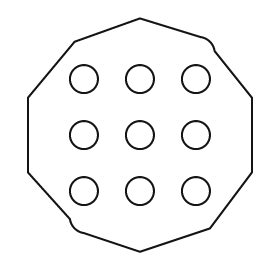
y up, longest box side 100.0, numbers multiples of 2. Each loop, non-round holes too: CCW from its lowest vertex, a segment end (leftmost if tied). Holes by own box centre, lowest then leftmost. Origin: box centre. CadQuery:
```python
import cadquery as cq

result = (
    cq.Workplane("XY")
    .moveTo(0.0, -50.0)
    .lineTo(30.0, -40.0)
    .lineTo(48.0, -16.0)
    .lineTo(48.0, 16.0)
    .lineTo(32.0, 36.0)
    .threePointArc((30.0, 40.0), (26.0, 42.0))
    .lineTo(0.0, 50.0)
    .lineTo(-28.0, 40.0)
    .lineTo(-48.0, 16.0)
    .lineTo(-48.0, -16.0)
    .lineTo(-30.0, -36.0)
    .threePointArc((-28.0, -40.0), (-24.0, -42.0))
    .close()
    .moveTo(-24.0, -24.0)
    .circle(6.0)
    .moveTo(0.0, -24.0)
    .circle(6.0)
    .moveTo(24.0, -24.0)
    .circle(6.0)
    .moveTo(-24.0, 0.0)
    .circle(6.0)
    .moveTo(0.0, 0.0)
    .circle(6.0)
    .moveTo(24.0, 0.0)
    .circle(6.0)
    .moveTo(-24.0, 24.0)
    .circle(6.0)
    .moveTo(0.0, 24.0)
    .circle(6.0)
    .moveTo(24.0, 24.0)
    .circle(6.0)
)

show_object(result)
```